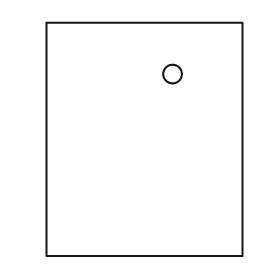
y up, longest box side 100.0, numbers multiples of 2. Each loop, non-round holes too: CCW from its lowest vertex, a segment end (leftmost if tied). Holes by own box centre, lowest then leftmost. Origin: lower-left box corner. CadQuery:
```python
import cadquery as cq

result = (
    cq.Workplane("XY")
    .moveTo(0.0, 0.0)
    .lineTo(84.0, 0.0)
    .lineTo(84.0, 100.0)
    .lineTo(0.0, 100.0)
    .close()
    .moveTo(54.0, 78.0)
    .circle(4.0)
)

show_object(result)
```